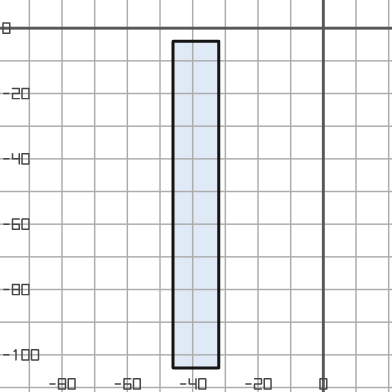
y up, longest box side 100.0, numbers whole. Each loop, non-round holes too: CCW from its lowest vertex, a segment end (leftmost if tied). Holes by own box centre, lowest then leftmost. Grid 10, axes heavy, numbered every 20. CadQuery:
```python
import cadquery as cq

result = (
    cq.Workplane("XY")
    .moveTo(-46.0, -104.0)
    .lineTo(-32.0, -104.0)
    .lineTo(-32.0, -4.0)
    .lineTo(-46.0, -4.0)
    .close()
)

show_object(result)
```